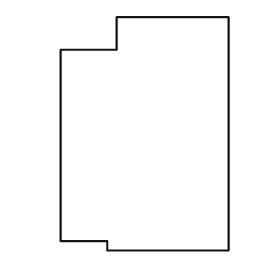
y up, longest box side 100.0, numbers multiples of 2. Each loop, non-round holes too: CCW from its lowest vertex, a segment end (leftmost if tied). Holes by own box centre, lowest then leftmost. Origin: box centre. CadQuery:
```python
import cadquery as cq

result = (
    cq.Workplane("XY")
    .moveTo(-16.0, -50.0)
    .lineTo(36.0, -50.0)
    .lineTo(36.0, 50.0)
    .lineTo(-12.0, 50.0)
    .lineTo(-12.0, 36.0)
    .lineTo(-36.0, 36.0)
    .lineTo(-36.0, -46.0)
    .lineTo(-16.0, -46.0)
    .close()
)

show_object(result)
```